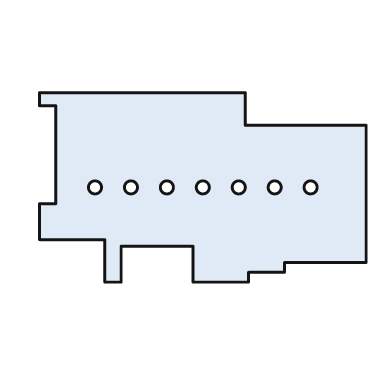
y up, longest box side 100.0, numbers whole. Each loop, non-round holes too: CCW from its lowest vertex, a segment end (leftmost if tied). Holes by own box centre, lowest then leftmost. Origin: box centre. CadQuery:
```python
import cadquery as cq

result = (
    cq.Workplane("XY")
    .moveTo(-30.0, -29.0)
    .lineTo(-25.0, -29.0)
    .lineTo(-25.0, -18.0)
    .lineTo(-3.0, -18.0)
    .lineTo(-3.0, -29.0)
    .lineTo(14.0, -29.0)
    .lineTo(14.0, -26.0)
    .lineTo(25.0, -26.0)
    .lineTo(25.0, -23.0)
    .lineTo(50.0, -23.0)
    .lineTo(50.0, 19.0)
    .lineTo(13.0, 19.0)
    .lineTo(13.0, 29.0)
    .lineTo(-50.0, 29.0)
    .lineTo(-50.0, 25.0)
    .lineTo(-45.0, 25.0)
    .lineTo(-45.0, -5.0)
    .lineTo(-50.0, -5.0)
    .lineTo(-50.0, -16.0)
    .lineTo(-30.0, -16.0)
    .close()
    .moveTo(-33.0, 0.0)
    .circle(2.0)
    .moveTo(-22.0, 0.0)
    .circle(2.0)
    .moveTo(-11.0, 0.0)
    .circle(2.0)
    .moveTo(0.0, 0.0)
    .circle(2.0)
    .moveTo(11.0, 0.0)
    .circle(2.0)
    .moveTo(22.0, 0.0)
    .circle(2.0)
    .moveTo(33.0, 0.0)
    .circle(2.0)
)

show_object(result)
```